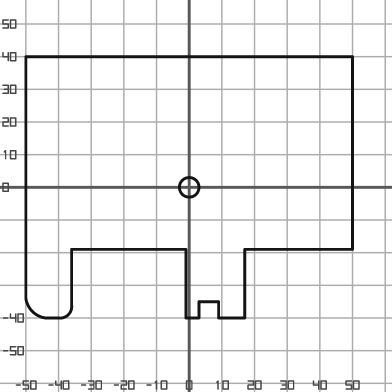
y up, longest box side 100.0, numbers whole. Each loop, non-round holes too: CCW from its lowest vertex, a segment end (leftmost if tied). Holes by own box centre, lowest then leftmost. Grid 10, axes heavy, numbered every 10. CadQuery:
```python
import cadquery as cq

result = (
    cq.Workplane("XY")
    .moveTo(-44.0, -40.0)
    .lineTo(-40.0, -40.0)
    .threePointArc((-37.0, -39.0), (-36.0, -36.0))
    .lineTo(-36.0, -19.0)
    .lineTo(-1.0, -19.0)
    .lineTo(-1.0, -40.0)
    .lineTo(3.0, -40.0)
    .lineTo(3.0, -35.0)
    .lineTo(9.0, -35.0)
    .lineTo(9.0, -40.0)
    .lineTo(17.0, -40.0)
    .lineTo(17.0, -19.0)
    .lineTo(50.0, -19.0)
    .lineTo(50.0, 40.0)
    .lineTo(-50.0, 40.0)
    .lineTo(-50.0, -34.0)
    .threePointArc((-48.0, -38.0), (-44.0, -40.0))
    .close()
    .moveTo(0.0, 0.0)
    .circle(3.0)
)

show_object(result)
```